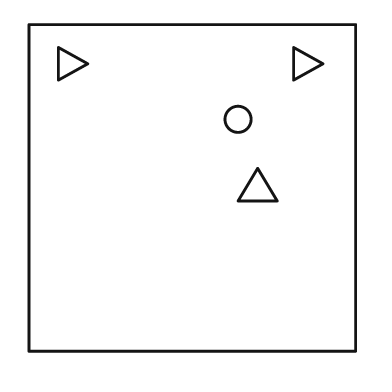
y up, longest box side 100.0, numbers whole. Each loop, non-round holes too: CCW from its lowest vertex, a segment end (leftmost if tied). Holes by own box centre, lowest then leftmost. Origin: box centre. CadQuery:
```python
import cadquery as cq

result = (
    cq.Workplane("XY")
    .moveTo(-50.0, -50.0)
    .lineTo(50.0, -50.0)
    .lineTo(50.0, 50.0)
    .lineTo(-50.0, 50.0)
    .close()
    .moveTo(14.0, -4.0)
    .lineTo(26.0, -4.0)
    .lineTo(20.0, 6.0)
    .close()
    .moveTo(14.0, 21.0)
    .circle(4.0)
    .moveTo(-41.0, 33.0)
    .lineTo(-32.0, 38.0)
    .lineTo(-41.0, 43.0)
    .close()
    .moveTo(31.0, 33.0)
    .lineTo(40.0, 38.0)
    .lineTo(31.0, 43.0)
    .close()
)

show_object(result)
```